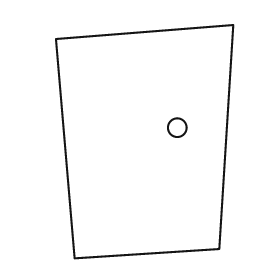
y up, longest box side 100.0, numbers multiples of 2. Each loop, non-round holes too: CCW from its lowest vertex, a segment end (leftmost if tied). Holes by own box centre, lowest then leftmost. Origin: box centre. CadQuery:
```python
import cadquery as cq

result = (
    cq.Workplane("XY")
    .moveTo(-30.0, -50.0)
    .lineTo(32.0, -46.0)
    .lineTo(38.0, 50.0)
    .lineTo(-38.0, 44.0)
    .close()
    .moveTo(14.0, 6.0)
    .circle(4.0)
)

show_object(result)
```